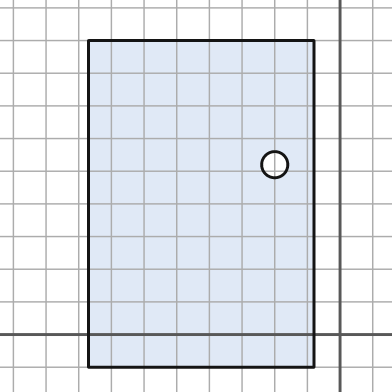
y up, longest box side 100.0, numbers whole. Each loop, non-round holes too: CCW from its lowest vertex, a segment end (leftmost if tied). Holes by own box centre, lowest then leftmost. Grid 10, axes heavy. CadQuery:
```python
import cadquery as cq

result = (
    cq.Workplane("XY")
    .moveTo(-77.0, -10.0)
    .lineTo(-8.0, -10.0)
    .lineTo(-8.0, 90.0)
    .lineTo(-77.0, 90.0)
    .close()
    .moveTo(-20.0, 52.0)
    .circle(4.0)
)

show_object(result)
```